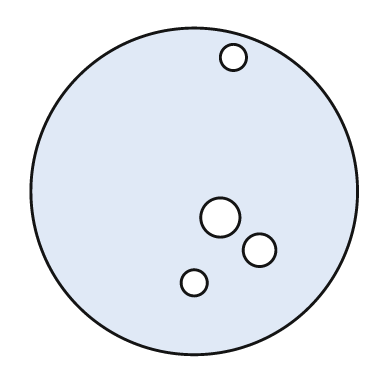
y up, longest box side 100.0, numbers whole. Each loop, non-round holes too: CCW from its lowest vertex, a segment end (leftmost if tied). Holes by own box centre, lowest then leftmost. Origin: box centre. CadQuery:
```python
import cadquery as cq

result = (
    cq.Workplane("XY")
    .moveTo(0.0, 0.0)
    .circle(50.0)
    .moveTo(0.0, -28.0)
    .circle(4.0)
    .moveTo(20.0, -18.0)
    .circle(5.0)
    .moveTo(8.0, -8.0)
    .circle(6.0)
    .moveTo(12.0, 41.0)
    .circle(4.0)
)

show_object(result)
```